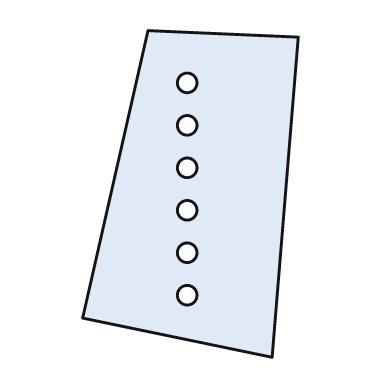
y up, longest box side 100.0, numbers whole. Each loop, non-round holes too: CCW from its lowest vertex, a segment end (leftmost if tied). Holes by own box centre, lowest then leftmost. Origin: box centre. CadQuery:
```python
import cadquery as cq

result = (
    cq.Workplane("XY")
    .moveTo(25.0, -50.0)
    .lineTo(33.0, 48.0)
    .lineTo(-13.0, 50.0)
    .lineTo(-33.0, -38.0)
    .close()
    .moveTo(-1.0, -31.0)
    .circle(3.0)
    .moveTo(-1.0, -18.0)
    .circle(3.0)
    .moveTo(-1.0, -5.0)
    .circle(3.0)
    .moveTo(-1.0, 8.0)
    .circle(3.0)
    .moveTo(-1.0, 21.0)
    .circle(3.0)
    .moveTo(-1.0, 34.0)
    .circle(3.0)
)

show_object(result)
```